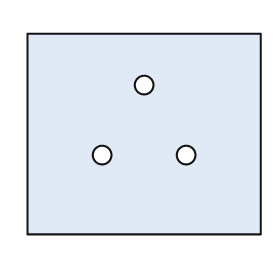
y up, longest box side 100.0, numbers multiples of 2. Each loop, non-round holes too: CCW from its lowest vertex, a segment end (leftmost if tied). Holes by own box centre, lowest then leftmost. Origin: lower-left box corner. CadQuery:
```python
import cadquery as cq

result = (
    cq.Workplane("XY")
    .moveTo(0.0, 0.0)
    .lineTo(100.0, 0.0)
    .lineTo(100.0, 86.0)
    .lineTo(0.0, 86.0)
    .close()
    .moveTo(32.0, 34.0)
    .circle(4.0)
    .moveTo(68.0, 34.0)
    .circle(4.0)
    .moveTo(50.0, 64.0)
    .circle(4.0)
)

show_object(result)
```